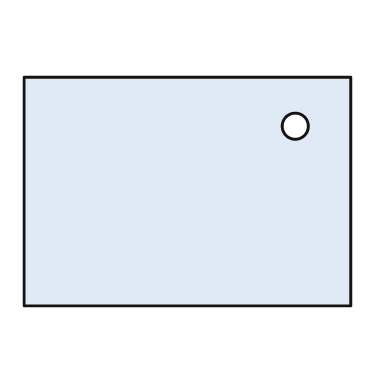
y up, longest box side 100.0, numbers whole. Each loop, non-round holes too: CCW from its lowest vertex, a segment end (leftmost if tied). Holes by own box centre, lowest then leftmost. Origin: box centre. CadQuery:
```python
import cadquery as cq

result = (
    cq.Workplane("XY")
    .moveTo(-50.0, -35.0)
    .lineTo(50.0, -35.0)
    .lineTo(50.0, 35.0)
    .lineTo(-50.0, 35.0)
    .close()
    .moveTo(33.0, 20.0)
    .circle(4.0)
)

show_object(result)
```